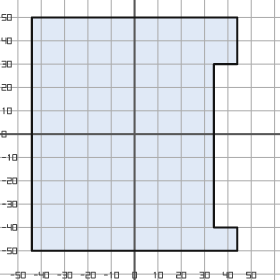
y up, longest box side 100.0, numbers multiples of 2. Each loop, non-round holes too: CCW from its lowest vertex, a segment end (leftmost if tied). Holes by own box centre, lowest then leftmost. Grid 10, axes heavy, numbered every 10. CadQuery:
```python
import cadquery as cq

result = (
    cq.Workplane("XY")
    .moveTo(-44.0, -50.0)
    .lineTo(44.0, -50.0)
    .lineTo(44.0, -40.0)
    .lineTo(34.0, -40.0)
    .lineTo(34.0, 30.0)
    .lineTo(44.0, 30.0)
    .lineTo(44.0, 50.0)
    .lineTo(-44.0, 50.0)
    .close()
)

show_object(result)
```